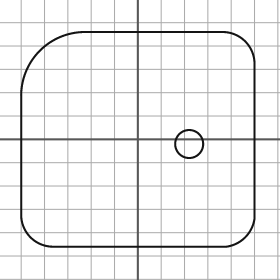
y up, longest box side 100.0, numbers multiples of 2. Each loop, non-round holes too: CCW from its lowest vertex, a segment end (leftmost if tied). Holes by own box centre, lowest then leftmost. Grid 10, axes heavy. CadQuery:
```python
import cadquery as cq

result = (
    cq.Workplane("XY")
    .moveTo(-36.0, -46.0)
    .lineTo(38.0, -46.0)
    .threePointArc((46.0, -42.0), (50.0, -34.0))
    .lineTo(50.0, 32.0)
    .threePointArc((46.0, 42.0), (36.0, 46.0))
    .lineTo(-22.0, 46.0)
    .threePointArc((-42.0, 38.0), (-50.0, 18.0))
    .lineTo(-50.0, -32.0)
    .threePointArc((-46.0, -42.0), (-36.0, -46.0))
    .close()
    .moveTo(22.0, -2.0)
    .circle(6.0)
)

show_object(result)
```